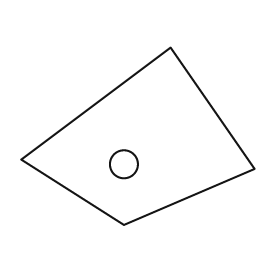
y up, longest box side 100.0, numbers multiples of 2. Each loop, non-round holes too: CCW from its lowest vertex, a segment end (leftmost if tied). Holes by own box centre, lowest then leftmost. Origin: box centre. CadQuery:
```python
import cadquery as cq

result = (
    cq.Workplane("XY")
    .moveTo(-6.0, -38.0)
    .lineTo(50.0, -14.0)
    .lineTo(14.0, 38.0)
    .lineTo(-50.0, -10.0)
    .close()
    .moveTo(-6.0, -12.0)
    .circle(6.0)
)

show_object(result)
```